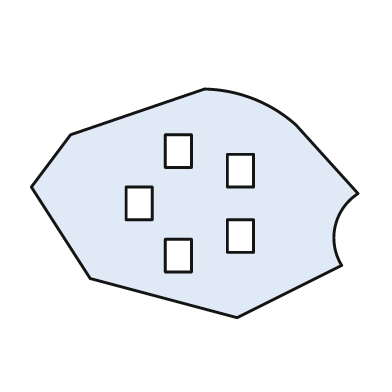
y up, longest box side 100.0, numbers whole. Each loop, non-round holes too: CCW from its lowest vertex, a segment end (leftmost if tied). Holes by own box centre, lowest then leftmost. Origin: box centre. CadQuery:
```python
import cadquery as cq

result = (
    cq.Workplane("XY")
    .moveTo(13.0, -35.0)
    .lineTo(45.0, -19.0)
    .threePointArc((43.0, -7.0), (50.0, 3.0))
    .lineTo(31.0, 24.0)
    .threePointArc((18.0, 32.0), (3.0, 35.0))
    .lineTo(-38.0, 21.0)
    .lineTo(-50.0, 5.0)
    .lineTo(-32.0, -23.0)
    .close()
    .moveTo(-9.0, -21.0)
    .lineTo(-1.0, -21.0)
    .lineTo(-1.0, -11.0)
    .lineTo(-9.0, -11.0)
    .close()
    .moveTo(10.0, -15.0)
    .lineTo(18.0, -15.0)
    .lineTo(18.0, -5.0)
    .lineTo(10.0, -5.0)
    .close()
    .moveTo(-21.0, -5.0)
    .lineTo(-13.0, -5.0)
    .lineTo(-13.0, 5.0)
    .lineTo(-21.0, 5.0)
    .close()
    .moveTo(10.0, 5.0)
    .lineTo(18.0, 5.0)
    .lineTo(18.0, 15.0)
    .lineTo(10.0, 15.0)
    .close()
    .moveTo(-9.0, 11.0)
    .lineTo(-1.0, 11.0)
    .lineTo(-1.0, 21.0)
    .lineTo(-9.0, 21.0)
    .close()
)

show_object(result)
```